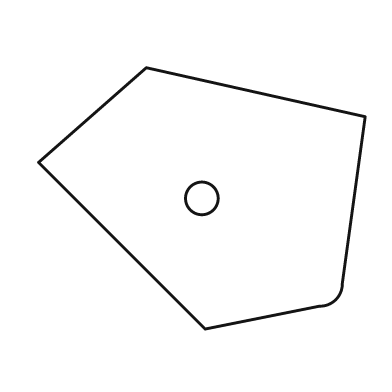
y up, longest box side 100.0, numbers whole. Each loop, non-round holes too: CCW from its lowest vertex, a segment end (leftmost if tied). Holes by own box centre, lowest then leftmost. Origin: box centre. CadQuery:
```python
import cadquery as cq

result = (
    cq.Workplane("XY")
    .moveTo(1.0, -40.0)
    .lineTo(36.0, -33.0)
    .threePointArc((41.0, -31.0), (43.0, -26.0))
    .lineTo(50.0, 25.0)
    .lineTo(-17.0, 40.0)
    .lineTo(-50.0, 11.0)
    .close()
    .moveTo(0.0, 0.0)
    .circle(5.0)
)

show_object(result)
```